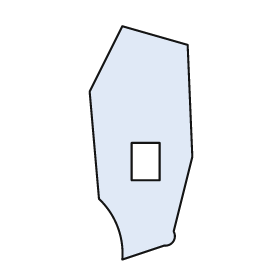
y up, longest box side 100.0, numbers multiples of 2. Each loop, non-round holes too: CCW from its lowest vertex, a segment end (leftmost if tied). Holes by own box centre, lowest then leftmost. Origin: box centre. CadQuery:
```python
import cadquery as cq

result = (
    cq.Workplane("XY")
    .moveTo(-8.0, -50.0)
    .lineTo(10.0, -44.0)
    .threePointArc((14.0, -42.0), (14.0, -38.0))
    .lineTo(22.0, -6.0)
    .lineTo(20.0, 42.0)
    .lineTo(-8.0, 50.0)
    .lineTo(-22.0, 22.0)
    .lineTo(-18.0, -24.0)
    .threePointArc((-10.0, -36.0), (-8.0, -50.0))
    .close()
    .moveTo(-4.0, -16.0)
    .lineTo(8.0, -16.0)
    .lineTo(8.0, 0.0)
    .lineTo(-4.0, 0.0)
    .close()
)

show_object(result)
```